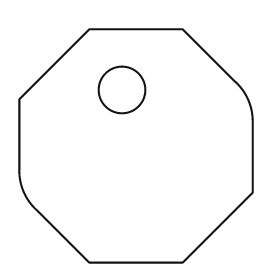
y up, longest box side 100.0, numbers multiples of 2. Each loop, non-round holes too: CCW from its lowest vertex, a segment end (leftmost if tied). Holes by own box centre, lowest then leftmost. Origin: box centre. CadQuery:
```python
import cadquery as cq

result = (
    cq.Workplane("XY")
    .moveTo(-20.0, -50.0)
    .lineTo(20.0, -50.0)
    .lineTo(50.0, -20.0)
    .lineTo(50.0, 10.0)
    .threePointArc((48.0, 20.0), (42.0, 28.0))
    .lineTo(20.0, 50.0)
    .lineTo(-20.0, 50.0)
    .lineTo(-50.0, 20.0)
    .lineTo(-50.0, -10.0)
    .threePointArc((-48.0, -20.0), (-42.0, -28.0))
    .close()
    .moveTo(-6.0, 24.0)
    .circle(10.0)
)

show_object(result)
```